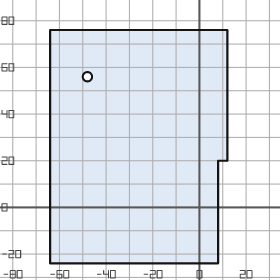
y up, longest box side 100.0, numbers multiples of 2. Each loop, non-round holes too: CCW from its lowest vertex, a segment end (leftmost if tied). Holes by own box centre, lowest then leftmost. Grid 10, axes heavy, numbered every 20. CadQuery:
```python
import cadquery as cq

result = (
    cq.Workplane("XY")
    .moveTo(-64.0, -24.0)
    .lineTo(8.0, -24.0)
    .lineTo(8.0, 20.0)
    .lineTo(12.0, 20.0)
    .lineTo(12.0, 76.0)
    .lineTo(-64.0, 76.0)
    .close()
    .moveTo(-48.0, 56.0)
    .circle(2.0)
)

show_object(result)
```